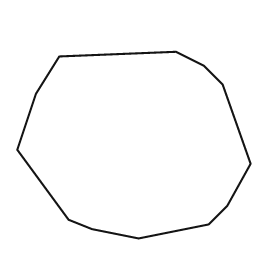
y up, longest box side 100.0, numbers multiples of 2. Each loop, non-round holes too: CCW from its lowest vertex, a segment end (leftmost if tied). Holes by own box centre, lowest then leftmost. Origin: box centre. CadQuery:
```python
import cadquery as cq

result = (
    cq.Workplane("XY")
    .moveTo(2.0, -40.0)
    .lineTo(32.0, -34.0)
    .lineTo(40.0, -26.0)
    .lineTo(50.0, -8.0)
    .lineTo(38.0, 26.0)
    .lineTo(30.0, 34.0)
    .lineTo(18.0, 40.0)
    .lineTo(-32.0, 38.0)
    .lineTo(-42.0, 22.0)
    .lineTo(-50.0, -2.0)
    .lineTo(-28.0, -32.0)
    .lineTo(-18.0, -36.0)
    .close()
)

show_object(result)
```